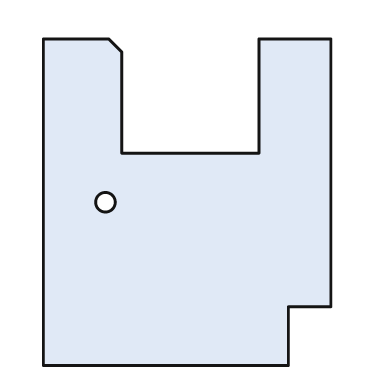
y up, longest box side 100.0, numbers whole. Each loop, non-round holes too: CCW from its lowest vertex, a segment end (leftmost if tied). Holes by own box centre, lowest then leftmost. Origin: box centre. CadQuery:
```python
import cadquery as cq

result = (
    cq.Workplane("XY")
    .moveTo(-44.0, -50.0)
    .lineTo(31.0, -50.0)
    .lineTo(31.0, -32.0)
    .lineTo(44.0, -32.0)
    .lineTo(44.0, 50.0)
    .lineTo(22.0, 50.0)
    .lineTo(22.0, 15.0)
    .lineTo(-20.0, 15.0)
    .lineTo(-20.0, 46.0)
    .lineTo(-24.0, 50.0)
    .lineTo(-44.0, 50.0)
    .close()
    .moveTo(-25.0, 0.0)
    .circle(3.0)
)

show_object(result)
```